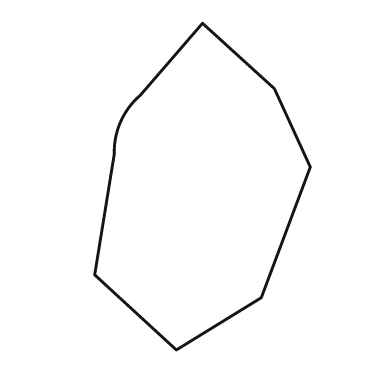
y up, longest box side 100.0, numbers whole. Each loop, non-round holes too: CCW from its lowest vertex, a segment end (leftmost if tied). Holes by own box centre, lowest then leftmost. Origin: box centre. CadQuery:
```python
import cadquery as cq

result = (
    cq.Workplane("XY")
    .moveTo(-8.0, -50.0)
    .lineTo(18.0, -34.0)
    .lineTo(33.0, 6.0)
    .lineTo(22.0, 30.0)
    .lineTo(0.0, 50.0)
    .lineTo(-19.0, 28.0)
    .threePointArc((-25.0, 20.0), (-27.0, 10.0))
    .lineTo(-33.0, -27.0)
    .close()
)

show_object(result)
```